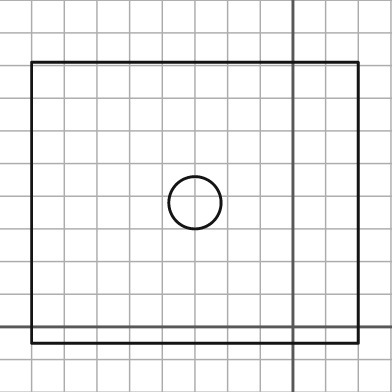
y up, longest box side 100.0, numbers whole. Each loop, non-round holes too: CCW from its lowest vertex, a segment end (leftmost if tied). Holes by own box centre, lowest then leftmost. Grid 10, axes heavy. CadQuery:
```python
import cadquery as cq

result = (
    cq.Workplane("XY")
    .moveTo(-80.0, -5.0)
    .lineTo(20.0, -5.0)
    .lineTo(20.0, 81.0)
    .lineTo(-80.0, 81.0)
    .close()
    .moveTo(-30.0, 38.0)
    .circle(8.0)
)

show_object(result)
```